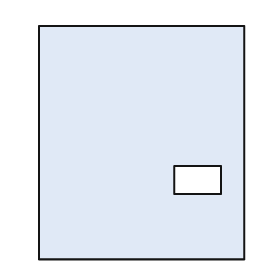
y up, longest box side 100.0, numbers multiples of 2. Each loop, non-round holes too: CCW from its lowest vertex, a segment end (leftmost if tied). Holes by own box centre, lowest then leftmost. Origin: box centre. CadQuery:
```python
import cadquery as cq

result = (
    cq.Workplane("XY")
    .moveTo(-44.0, -50.0)
    .lineTo(44.0, -50.0)
    .lineTo(44.0, 50.0)
    .lineTo(-44.0, 50.0)
    .close()
    .moveTo(14.0, -22.0)
    .lineTo(34.0, -22.0)
    .lineTo(34.0, -10.0)
    .lineTo(14.0, -10.0)
    .close()
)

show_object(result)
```